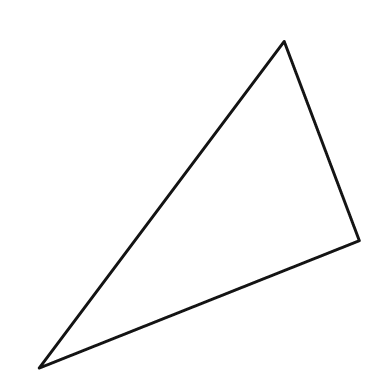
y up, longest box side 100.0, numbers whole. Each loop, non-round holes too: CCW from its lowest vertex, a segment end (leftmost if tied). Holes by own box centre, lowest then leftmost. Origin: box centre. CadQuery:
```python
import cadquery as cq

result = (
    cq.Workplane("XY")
    .moveTo(-49.0, -50.0)
    .lineTo(49.0, -11.0)
    .lineTo(26.0, 50.0)
    .close()
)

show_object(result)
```